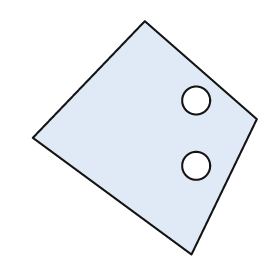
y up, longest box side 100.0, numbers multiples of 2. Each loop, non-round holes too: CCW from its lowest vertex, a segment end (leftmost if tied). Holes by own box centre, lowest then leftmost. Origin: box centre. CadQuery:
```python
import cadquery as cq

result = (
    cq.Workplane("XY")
    .moveTo(20.0, -50.0)
    .lineTo(48.0, 8.0)
    .lineTo(0.0, 50.0)
    .lineTo(-48.0, 0.0)
    .close()
    .moveTo(22.0, -12.0)
    .circle(6.0)
    .moveTo(22.0, 16.0)
    .circle(6.0)
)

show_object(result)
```